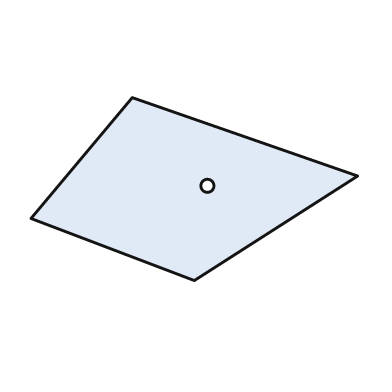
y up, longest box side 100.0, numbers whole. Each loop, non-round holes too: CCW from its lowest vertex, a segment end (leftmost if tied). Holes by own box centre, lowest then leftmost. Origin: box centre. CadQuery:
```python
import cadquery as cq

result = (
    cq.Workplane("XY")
    .moveTo(0.0, -28.0)
    .lineTo(50.0, 4.0)
    .lineTo(-19.0, 28.0)
    .lineTo(-50.0, -9.0)
    .close()
    .moveTo(4.0, 1.0)
    .circle(2.0)
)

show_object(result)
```